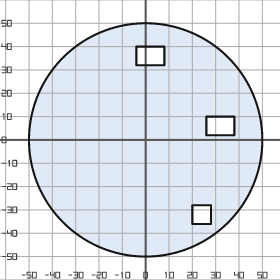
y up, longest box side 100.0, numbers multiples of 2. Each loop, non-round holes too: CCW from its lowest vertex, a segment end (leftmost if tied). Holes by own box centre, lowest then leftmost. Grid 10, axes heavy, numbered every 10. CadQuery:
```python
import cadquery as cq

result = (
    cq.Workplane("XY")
    .moveTo(0.0, 0.0)
    .circle(50.0)
    .moveTo(20.0, -36.0)
    .lineTo(28.0, -36.0)
    .lineTo(28.0, -28.0)
    .lineTo(20.0, -28.0)
    .close()
    .moveTo(26.0, 2.0)
    .lineTo(38.0, 2.0)
    .lineTo(38.0, 10.0)
    .lineTo(26.0, 10.0)
    .close()
    .moveTo(-4.0, 32.0)
    .lineTo(8.0, 32.0)
    .lineTo(8.0, 40.0)
    .lineTo(-4.0, 40.0)
    .close()
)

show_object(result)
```